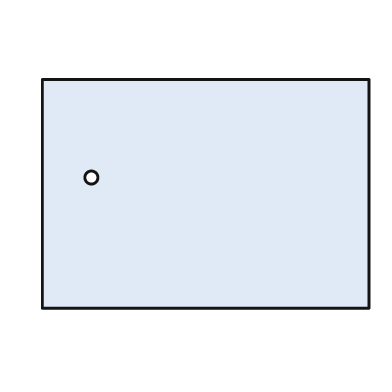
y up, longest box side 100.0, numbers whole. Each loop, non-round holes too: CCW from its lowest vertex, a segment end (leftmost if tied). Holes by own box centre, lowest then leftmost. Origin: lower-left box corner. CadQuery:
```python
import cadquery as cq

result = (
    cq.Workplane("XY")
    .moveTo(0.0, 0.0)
    .lineTo(100.0, 0.0)
    .lineTo(100.0, 70.0)
    .lineTo(0.0, 70.0)
    .close()
    .moveTo(15.0, 40.0)
    .circle(2.0)
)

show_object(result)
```